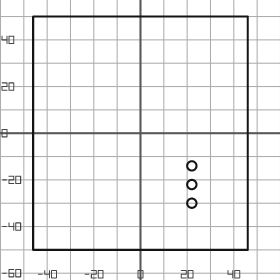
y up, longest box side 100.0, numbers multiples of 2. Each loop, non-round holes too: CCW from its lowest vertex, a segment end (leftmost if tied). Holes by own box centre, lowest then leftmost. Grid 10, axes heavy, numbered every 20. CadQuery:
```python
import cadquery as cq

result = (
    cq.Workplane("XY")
    .moveTo(-46.0, -50.0)
    .lineTo(46.0, -50.0)
    .lineTo(46.0, 50.0)
    .lineTo(-46.0, 50.0)
    .close()
    .moveTo(22.0, -30.0)
    .circle(2.0)
    .moveTo(22.0, -22.0)
    .circle(2.0)
    .moveTo(22.0, -14.0)
    .circle(2.0)
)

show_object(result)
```